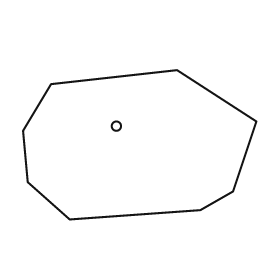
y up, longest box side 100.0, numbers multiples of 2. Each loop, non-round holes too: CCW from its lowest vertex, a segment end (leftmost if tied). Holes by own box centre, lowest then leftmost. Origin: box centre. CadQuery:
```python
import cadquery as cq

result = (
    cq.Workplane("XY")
    .moveTo(-30.0, -32.0)
    .lineTo(26.0, -28.0)
    .lineTo(40.0, -20.0)
    .lineTo(50.0, 10.0)
    .lineTo(16.0, 32.0)
    .lineTo(-38.0, 26.0)
    .lineTo(-50.0, 6.0)
    .lineTo(-48.0, -16.0)
    .close()
    .moveTo(-10.0, 8.0)
    .circle(2.0)
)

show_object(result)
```